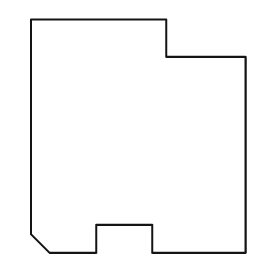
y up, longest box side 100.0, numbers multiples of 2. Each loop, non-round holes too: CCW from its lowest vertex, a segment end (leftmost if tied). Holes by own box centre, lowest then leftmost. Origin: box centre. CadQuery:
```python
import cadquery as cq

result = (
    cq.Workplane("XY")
    .moveTo(-38.0, -50.0)
    .lineTo(-18.0, -50.0)
    .lineTo(-18.0, -38.0)
    .lineTo(6.0, -38.0)
    .lineTo(6.0, -50.0)
    .lineTo(46.0, -50.0)
    .lineTo(46.0, 34.0)
    .lineTo(12.0, 34.0)
    .lineTo(12.0, 50.0)
    .lineTo(-46.0, 50.0)
    .lineTo(-46.0, -42.0)
    .close()
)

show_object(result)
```